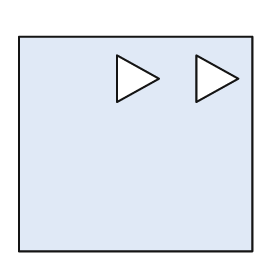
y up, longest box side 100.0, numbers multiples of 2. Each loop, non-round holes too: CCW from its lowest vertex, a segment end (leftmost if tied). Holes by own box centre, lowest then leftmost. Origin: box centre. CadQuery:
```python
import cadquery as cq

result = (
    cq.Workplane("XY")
    .moveTo(-50.0, -46.0)
    .lineTo(50.0, -46.0)
    .lineTo(50.0, 46.0)
    .lineTo(-50.0, 46.0)
    .close()
    .moveTo(-8.0, 18.0)
    .lineTo(10.0, 28.0)
    .lineTo(-8.0, 38.0)
    .close()
    .moveTo(26.0, 18.0)
    .lineTo(44.0, 28.0)
    .lineTo(26.0, 38.0)
    .close()
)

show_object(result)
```